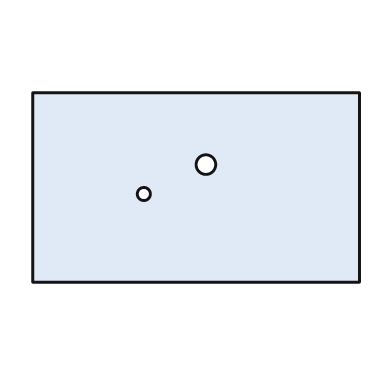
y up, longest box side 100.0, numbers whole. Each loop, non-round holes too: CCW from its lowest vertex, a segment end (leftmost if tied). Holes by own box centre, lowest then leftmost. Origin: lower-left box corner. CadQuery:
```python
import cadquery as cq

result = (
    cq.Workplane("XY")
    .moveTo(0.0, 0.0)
    .lineTo(100.0, 0.0)
    .lineTo(100.0, 58.0)
    .lineTo(0.0, 58.0)
    .close()
    .moveTo(34.0, 27.0)
    .circle(2.0)
    .moveTo(53.0, 36.0)
    .circle(3.0)
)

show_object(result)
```